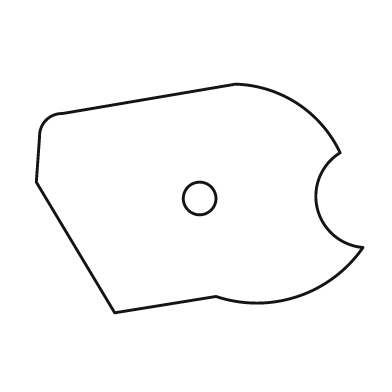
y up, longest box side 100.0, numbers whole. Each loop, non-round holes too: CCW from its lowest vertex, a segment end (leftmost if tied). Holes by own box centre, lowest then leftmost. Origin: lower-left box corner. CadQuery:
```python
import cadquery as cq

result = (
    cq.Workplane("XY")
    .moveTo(24.0, 0.0)
    .lineTo(55.0, 5.0)
    .threePointArc((80.0, 5.0), (100.0, 20.0))
    .threePointArc((86.0, 32.0), (93.0, 49.0))
    .threePointArc((80.0, 64.0), (61.0, 70.0))
    .lineTo(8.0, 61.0)
    .threePointArc((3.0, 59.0), (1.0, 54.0))
    .lineTo(0.0, 40.0)
    .close()
    .moveTo(50.0, 35.0)
    .circle(5.0)
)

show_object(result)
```